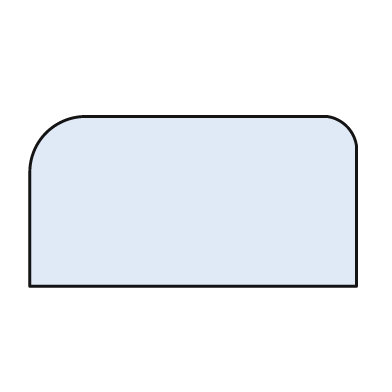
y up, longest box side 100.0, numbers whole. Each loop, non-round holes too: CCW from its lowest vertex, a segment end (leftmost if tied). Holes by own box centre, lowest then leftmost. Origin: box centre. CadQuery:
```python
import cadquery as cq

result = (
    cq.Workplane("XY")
    .moveTo(-50.0, -26.0)
    .lineTo(50.0, -26.0)
    .lineTo(50.0, 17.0)
    .threePointArc((47.0, 23.0), (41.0, 26.0))
    .lineTo(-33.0, 26.0)
    .threePointArc((-45.0, 21.0), (-50.0, 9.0))
    .close()
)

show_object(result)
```